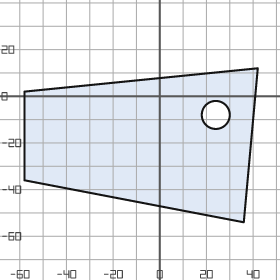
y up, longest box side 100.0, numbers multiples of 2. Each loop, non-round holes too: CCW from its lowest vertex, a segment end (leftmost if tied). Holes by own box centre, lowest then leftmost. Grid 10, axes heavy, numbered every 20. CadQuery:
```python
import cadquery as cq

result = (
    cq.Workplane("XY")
    .moveTo(36.0, -54.0)
    .lineTo(42.0, 12.0)
    .lineTo(-58.0, 2.0)
    .lineTo(-58.0, -36.0)
    .close()
    .moveTo(24.0, -8.0)
    .circle(6.0)
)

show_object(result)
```